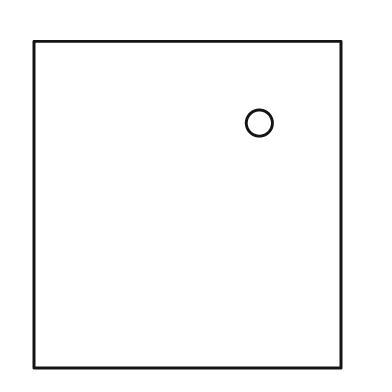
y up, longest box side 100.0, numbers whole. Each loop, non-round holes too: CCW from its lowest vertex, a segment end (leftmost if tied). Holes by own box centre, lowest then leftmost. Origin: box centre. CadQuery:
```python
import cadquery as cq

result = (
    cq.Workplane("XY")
    .moveTo(-47.0, -50.0)
    .lineTo(47.0, -50.0)
    .lineTo(47.0, 50.0)
    .lineTo(-47.0, 50.0)
    .close()
    .moveTo(22.0, 25.0)
    .circle(4.0)
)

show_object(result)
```